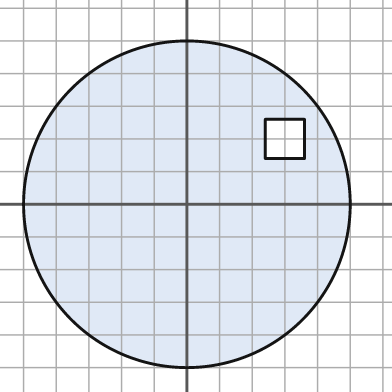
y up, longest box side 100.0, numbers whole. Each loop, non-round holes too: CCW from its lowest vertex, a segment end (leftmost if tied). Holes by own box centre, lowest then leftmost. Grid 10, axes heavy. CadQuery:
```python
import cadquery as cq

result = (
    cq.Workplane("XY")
    .moveTo(0.0, 0.0)
    .circle(50.0)
    .moveTo(24.0, 14.0)
    .lineTo(36.0, 14.0)
    .lineTo(36.0, 26.0)
    .lineTo(24.0, 26.0)
    .close()
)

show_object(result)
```